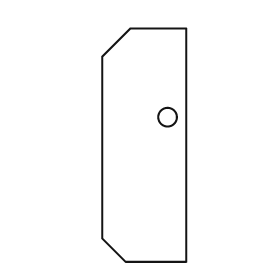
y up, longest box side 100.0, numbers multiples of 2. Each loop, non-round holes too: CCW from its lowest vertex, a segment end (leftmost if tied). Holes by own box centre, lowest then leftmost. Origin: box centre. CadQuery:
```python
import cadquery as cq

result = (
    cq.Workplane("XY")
    .moveTo(-8.0, -50.0)
    .lineTo(18.0, -50.0)
    .lineTo(18.0, 50.0)
    .lineTo(-6.0, 50.0)
    .lineTo(-18.0, 38.0)
    .lineTo(-18.0, -40.0)
    .close()
    .moveTo(10.0, 12.0)
    .circle(4.0)
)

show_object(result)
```